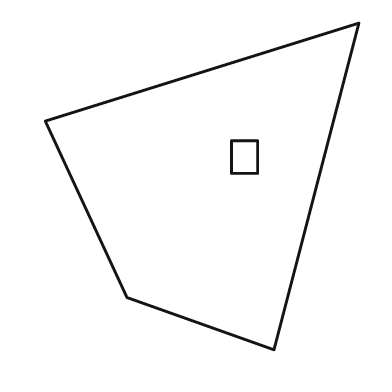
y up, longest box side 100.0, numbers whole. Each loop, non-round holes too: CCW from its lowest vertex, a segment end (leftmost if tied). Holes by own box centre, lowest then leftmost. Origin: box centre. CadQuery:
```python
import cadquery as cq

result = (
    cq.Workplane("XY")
    .moveTo(22.0, -50.0)
    .lineTo(48.0, 50.0)
    .lineTo(-48.0, 20.0)
    .lineTo(-23.0, -34.0)
    .close()
    .moveTo(9.0, 4.0)
    .lineTo(17.0, 4.0)
    .lineTo(17.0, 14.0)
    .lineTo(9.0, 14.0)
    .close()
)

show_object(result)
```